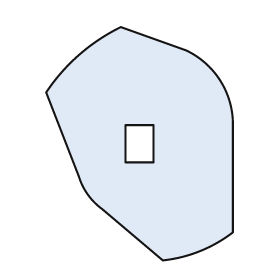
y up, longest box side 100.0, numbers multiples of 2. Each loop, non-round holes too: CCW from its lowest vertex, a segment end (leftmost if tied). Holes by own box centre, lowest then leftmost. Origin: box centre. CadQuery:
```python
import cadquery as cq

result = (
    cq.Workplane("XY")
    .moveTo(10.0, -50.0)
    .threePointArc((26.0, -46.0), (40.0, -38.0))
    .lineTo(40.0, 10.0)
    .threePointArc((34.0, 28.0), (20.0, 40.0))
    .lineTo(-8.0, 50.0)
    .threePointArc((-26.0, 38.0), (-40.0, 22.0))
    .lineTo(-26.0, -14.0)
    .threePointArc((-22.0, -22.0), (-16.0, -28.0))
    .close()
    .moveTo(-6.0, -8.0)
    .lineTo(6.0, -8.0)
    .lineTo(6.0, 8.0)
    .lineTo(-6.0, 8.0)
    .close()
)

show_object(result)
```